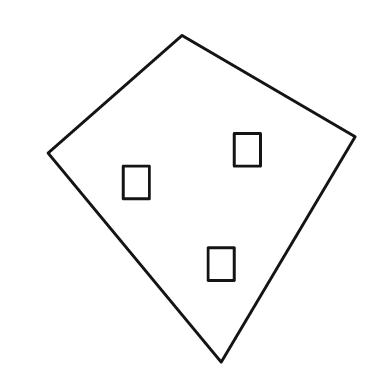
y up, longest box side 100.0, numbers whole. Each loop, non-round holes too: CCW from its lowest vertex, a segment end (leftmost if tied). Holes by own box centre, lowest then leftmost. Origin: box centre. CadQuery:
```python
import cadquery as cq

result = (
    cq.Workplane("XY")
    .moveTo(6.0, -50.0)
    .lineTo(47.0, 19.0)
    .lineTo(-6.0, 50.0)
    .lineTo(-47.0, 14.0)
    .close()
    .moveTo(2.0, -25.0)
    .lineTo(10.0, -25.0)
    .lineTo(10.0, -15.0)
    .lineTo(2.0, -15.0)
    .close()
    .moveTo(-24.0, 0.0)
    .lineTo(-16.0, 0.0)
    .lineTo(-16.0, 10.0)
    .lineTo(-24.0, 10.0)
    .close()
    .moveTo(10.0, 10.0)
    .lineTo(18.0, 10.0)
    .lineTo(18.0, 20.0)
    .lineTo(10.0, 20.0)
    .close()
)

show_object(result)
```